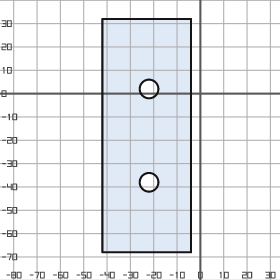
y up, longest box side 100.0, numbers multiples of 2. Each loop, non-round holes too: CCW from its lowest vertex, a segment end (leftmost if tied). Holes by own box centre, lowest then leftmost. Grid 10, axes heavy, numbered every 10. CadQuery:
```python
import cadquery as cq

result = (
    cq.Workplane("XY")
    .moveTo(-42.0, -68.0)
    .lineTo(-4.0, -68.0)
    .lineTo(-4.0, 32.0)
    .lineTo(-42.0, 32.0)
    .close()
    .moveTo(-22.0, -38.0)
    .circle(4.0)
    .moveTo(-22.0, 2.0)
    .circle(4.0)
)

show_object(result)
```